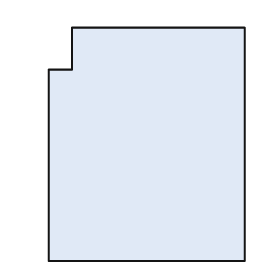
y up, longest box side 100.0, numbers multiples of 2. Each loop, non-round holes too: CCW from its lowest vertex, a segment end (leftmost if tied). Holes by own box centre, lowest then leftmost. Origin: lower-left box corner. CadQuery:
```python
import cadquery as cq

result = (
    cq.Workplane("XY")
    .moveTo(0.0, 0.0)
    .lineTo(84.0, 0.0)
    .lineTo(84.0, 100.0)
    .lineTo(10.0, 100.0)
    .lineTo(10.0, 82.0)
    .lineTo(0.0, 82.0)
    .close()
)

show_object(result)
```